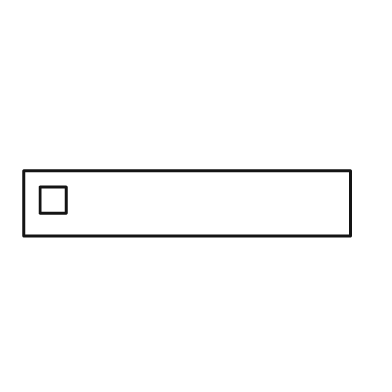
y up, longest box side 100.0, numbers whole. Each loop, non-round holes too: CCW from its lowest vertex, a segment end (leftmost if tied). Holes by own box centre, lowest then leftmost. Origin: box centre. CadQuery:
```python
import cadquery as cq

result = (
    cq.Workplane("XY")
    .moveTo(-50.0, -10.0)
    .lineTo(50.0, -10.0)
    .lineTo(50.0, 10.0)
    .lineTo(-50.0, 10.0)
    .close()
    .moveTo(-45.0, -3.0)
    .lineTo(-37.0, -3.0)
    .lineTo(-37.0, 5.0)
    .lineTo(-45.0, 5.0)
    .close()
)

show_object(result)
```